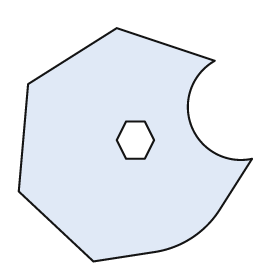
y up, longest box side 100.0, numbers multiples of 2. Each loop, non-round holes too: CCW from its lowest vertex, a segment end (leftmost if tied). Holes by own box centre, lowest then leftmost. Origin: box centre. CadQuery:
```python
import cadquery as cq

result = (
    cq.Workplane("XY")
    .moveTo(-18.0, -50.0)
    .lineTo(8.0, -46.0)
    .threePointArc((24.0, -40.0), (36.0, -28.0))
    .lineTo(50.0, -6.0)
    .threePointArc((24.0, 8.0), (34.0, 36.0))
    .lineTo(-8.0, 50.0)
    .lineTo(-46.0, 26.0)
    .lineTo(-50.0, -20.0)
    .close()
    .moveTo(-4.0, -6.0)
    .lineTo(4.0, -6.0)
    .lineTo(8.0, 2.0)
    .lineTo(4.0, 10.0)
    .lineTo(-4.0, 10.0)
    .lineTo(-8.0, 2.0)
    .close()
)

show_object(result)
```